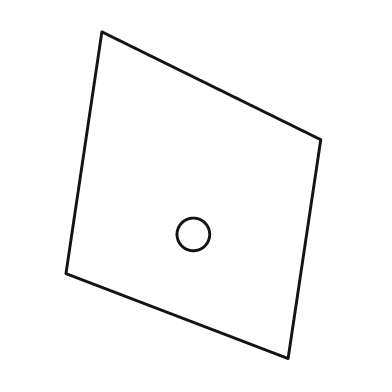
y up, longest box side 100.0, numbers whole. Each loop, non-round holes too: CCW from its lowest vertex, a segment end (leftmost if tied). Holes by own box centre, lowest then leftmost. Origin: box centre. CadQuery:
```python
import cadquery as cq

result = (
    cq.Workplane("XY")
    .moveTo(29.0, -50.0)
    .lineTo(39.0, 17.0)
    .lineTo(-28.0, 50.0)
    .lineTo(-39.0, -24.0)
    .close()
    .moveTo(0.0, -12.0)
    .circle(5.0)
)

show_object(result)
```